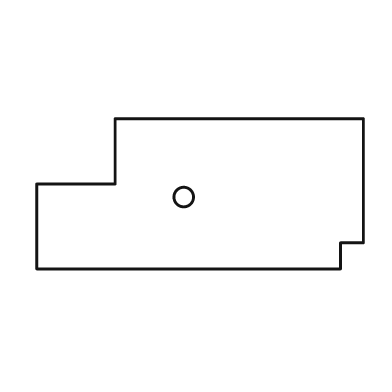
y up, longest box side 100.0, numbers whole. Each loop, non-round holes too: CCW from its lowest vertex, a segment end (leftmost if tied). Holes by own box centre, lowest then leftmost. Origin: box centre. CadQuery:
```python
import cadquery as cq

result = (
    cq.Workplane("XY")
    .moveTo(-50.0, -23.0)
    .lineTo(43.0, -23.0)
    .lineTo(43.0, -15.0)
    .lineTo(50.0, -15.0)
    .lineTo(50.0, 23.0)
    .lineTo(-26.0, 23.0)
    .lineTo(-26.0, 3.0)
    .lineTo(-50.0, 3.0)
    .close()
    .moveTo(-5.0, -1.0)
    .circle(3.0)
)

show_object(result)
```